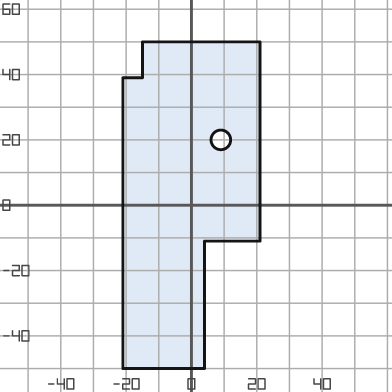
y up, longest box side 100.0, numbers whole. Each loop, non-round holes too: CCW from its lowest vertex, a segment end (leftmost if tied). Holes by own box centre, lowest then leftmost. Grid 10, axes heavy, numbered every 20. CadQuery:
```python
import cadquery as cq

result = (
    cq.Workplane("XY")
    .moveTo(-21.0, -50.0)
    .lineTo(4.0, -50.0)
    .lineTo(4.0, -11.0)
    .lineTo(21.0, -11.0)
    .lineTo(21.0, 50.0)
    .lineTo(-15.0, 50.0)
    .lineTo(-15.0, 39.0)
    .lineTo(-21.0, 39.0)
    .close()
    .moveTo(9.0, 20.0)
    .circle(3.0)
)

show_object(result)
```